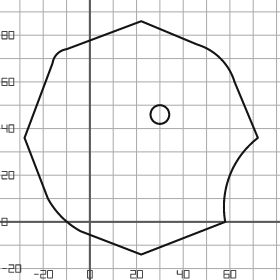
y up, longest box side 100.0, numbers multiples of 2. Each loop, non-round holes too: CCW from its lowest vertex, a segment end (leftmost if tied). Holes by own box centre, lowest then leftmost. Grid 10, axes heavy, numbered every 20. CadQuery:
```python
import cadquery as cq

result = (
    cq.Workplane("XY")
    .moveTo(22.0, -14.0)
    .lineTo(58.0, 0.0)
    .threePointArc((60.0, 20.0), (72.0, 36.0))
    .lineTo(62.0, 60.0)
    .threePointArc((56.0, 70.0), (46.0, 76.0))
    .lineTo(22.0, 86.0)
    .lineTo(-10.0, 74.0)
    .threePointArc((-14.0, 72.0), (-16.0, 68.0))
    .lineTo(-28.0, 36.0)
    .lineTo(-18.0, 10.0)
    .threePointArc((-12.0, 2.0), (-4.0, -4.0))
    .close()
    .moveTo(30.0, 46.0)
    .circle(4.0)
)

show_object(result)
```